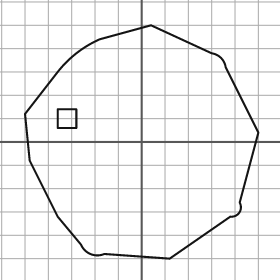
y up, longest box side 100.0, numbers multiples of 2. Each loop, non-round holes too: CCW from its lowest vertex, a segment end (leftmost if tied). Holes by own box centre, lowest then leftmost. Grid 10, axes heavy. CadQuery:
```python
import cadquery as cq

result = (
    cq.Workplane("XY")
    .moveTo(12.0, -50.0)
    .lineTo(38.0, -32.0)
    .threePointArc((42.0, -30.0), (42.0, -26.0))
    .lineTo(50.0, 4.0)
    .lineTo(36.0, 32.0)
    .threePointArc((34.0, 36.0), (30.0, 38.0))
    .lineTo(4.0, 50.0)
    .lineTo(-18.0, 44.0)
    .threePointArc((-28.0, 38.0), (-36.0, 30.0))
    .lineTo(-50.0, 12.0)
    .lineTo(-48.0, -8.0)
    .lineTo(-36.0, -32.0)
    .lineTo(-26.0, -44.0)
    .threePointArc((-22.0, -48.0), (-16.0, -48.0))
    .close()
    .moveTo(-36.0, 6.0)
    .lineTo(-28.0, 6.0)
    .lineTo(-28.0, 14.0)
    .lineTo(-36.0, 14.0)
    .close()
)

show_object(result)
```